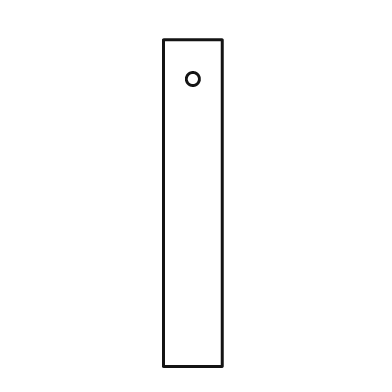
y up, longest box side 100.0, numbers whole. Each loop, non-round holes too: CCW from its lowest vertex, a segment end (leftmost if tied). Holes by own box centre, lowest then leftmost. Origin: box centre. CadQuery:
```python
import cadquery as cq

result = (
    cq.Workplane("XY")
    .moveTo(-9.0, -50.0)
    .lineTo(9.0, -50.0)
    .lineTo(9.0, 50.0)
    .lineTo(-9.0, 50.0)
    .close()
    .moveTo(0.0, 38.0)
    .circle(2.0)
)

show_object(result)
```